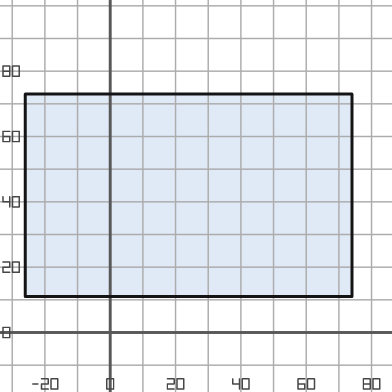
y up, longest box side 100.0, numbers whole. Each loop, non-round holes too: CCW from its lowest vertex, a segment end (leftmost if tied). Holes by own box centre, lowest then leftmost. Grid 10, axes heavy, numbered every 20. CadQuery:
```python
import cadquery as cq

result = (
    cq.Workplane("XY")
    .moveTo(-26.0, 11.0)
    .lineTo(74.0, 11.0)
    .lineTo(74.0, 73.0)
    .lineTo(-26.0, 73.0)
    .close()
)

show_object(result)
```